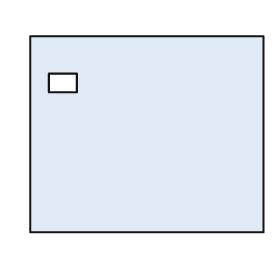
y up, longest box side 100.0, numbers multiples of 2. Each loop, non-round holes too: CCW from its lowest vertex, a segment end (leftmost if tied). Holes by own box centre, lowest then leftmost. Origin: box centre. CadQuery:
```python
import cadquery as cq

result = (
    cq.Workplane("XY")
    .moveTo(-50.0, -42.0)
    .lineTo(50.0, -42.0)
    .lineTo(50.0, 42.0)
    .lineTo(-50.0, 42.0)
    .close()
    .moveTo(-42.0, 18.0)
    .lineTo(-30.0, 18.0)
    .lineTo(-30.0, 26.0)
    .lineTo(-42.0, 26.0)
    .close()
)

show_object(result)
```